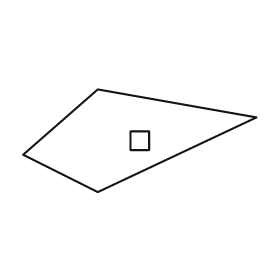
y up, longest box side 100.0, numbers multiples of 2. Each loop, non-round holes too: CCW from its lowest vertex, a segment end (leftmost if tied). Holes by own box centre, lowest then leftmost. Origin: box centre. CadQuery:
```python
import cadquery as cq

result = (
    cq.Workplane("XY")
    .moveTo(-18.0, -22.0)
    .lineTo(50.0, 10.0)
    .lineTo(-18.0, 22.0)
    .lineTo(-50.0, -6.0)
    .close()
    .moveTo(-4.0, -4.0)
    .lineTo(4.0, -4.0)
    .lineTo(4.0, 4.0)
    .lineTo(-4.0, 4.0)
    .close()
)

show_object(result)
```